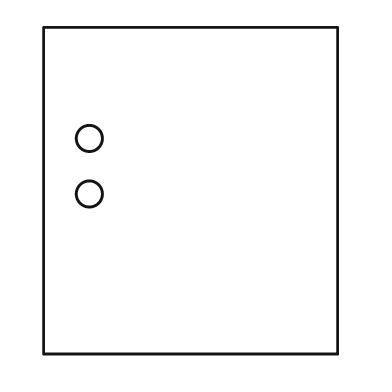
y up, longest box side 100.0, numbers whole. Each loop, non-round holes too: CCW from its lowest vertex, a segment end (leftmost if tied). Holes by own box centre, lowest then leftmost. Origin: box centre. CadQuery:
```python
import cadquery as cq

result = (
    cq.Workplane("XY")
    .moveTo(-45.0, -50.0)
    .lineTo(45.0, -50.0)
    .lineTo(45.0, 50.0)
    .lineTo(-45.0, 50.0)
    .close()
    .moveTo(-31.0, -1.0)
    .circle(4.0)
    .moveTo(-31.0, 16.0)
    .circle(4.0)
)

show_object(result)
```